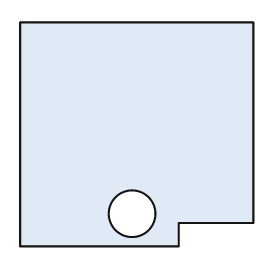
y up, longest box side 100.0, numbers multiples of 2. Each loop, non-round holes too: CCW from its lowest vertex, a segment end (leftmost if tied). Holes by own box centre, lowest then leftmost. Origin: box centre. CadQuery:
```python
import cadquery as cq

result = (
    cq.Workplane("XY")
    .moveTo(-50.0, -48.0)
    .lineTo(18.0, -48.0)
    .lineTo(18.0, -38.0)
    .lineTo(50.0, -38.0)
    .lineTo(50.0, 48.0)
    .lineTo(-50.0, 48.0)
    .close()
    .moveTo(-2.0, -34.0)
    .circle(10.0)
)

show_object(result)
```